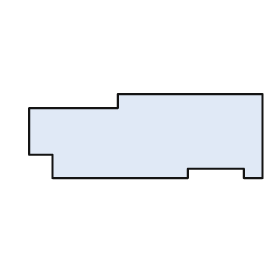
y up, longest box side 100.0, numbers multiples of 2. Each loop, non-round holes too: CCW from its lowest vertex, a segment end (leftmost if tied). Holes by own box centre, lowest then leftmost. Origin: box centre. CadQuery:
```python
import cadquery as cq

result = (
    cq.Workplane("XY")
    .moveTo(-40.0, -18.0)
    .lineTo(18.0, -18.0)
    .lineTo(18.0, -14.0)
    .lineTo(42.0, -14.0)
    .lineTo(42.0, -18.0)
    .lineTo(50.0, -18.0)
    .lineTo(50.0, 18.0)
    .lineTo(-12.0, 18.0)
    .lineTo(-12.0, 12.0)
    .lineTo(-50.0, 12.0)
    .lineTo(-50.0, -8.0)
    .lineTo(-40.0, -8.0)
    .close()
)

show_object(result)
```